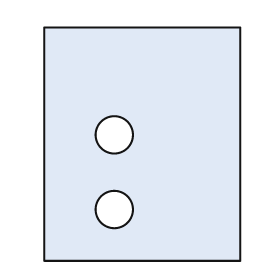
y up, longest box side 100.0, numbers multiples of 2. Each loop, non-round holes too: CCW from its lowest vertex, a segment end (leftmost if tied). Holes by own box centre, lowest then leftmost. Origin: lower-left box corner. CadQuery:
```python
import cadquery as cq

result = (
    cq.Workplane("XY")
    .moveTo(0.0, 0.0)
    .lineTo(84.0, 0.0)
    .lineTo(84.0, 100.0)
    .lineTo(0.0, 100.0)
    .close()
    .moveTo(30.0, 22.0)
    .circle(8.0)
    .moveTo(30.0, 54.0)
    .circle(8.0)
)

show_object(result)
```